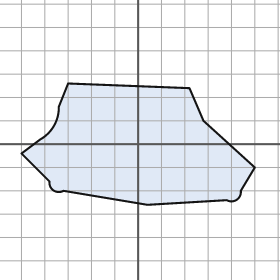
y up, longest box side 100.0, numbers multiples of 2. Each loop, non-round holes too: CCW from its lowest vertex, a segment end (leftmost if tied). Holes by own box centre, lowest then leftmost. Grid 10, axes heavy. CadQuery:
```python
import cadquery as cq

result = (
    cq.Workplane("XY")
    .moveTo(4.0, -26.0)
    .lineTo(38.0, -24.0)
    .threePointArc((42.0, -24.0), (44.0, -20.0))
    .lineTo(50.0, -10.0)
    .lineTo(28.0, 10.0)
    .lineTo(22.0, 24.0)
    .lineTo(-30.0, 26.0)
    .lineTo(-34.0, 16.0)
    .threePointArc((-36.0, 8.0), (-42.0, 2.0))
    .lineTo(-50.0, -4.0)
    .lineTo(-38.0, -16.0)
    .threePointArc((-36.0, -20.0), (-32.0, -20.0))
    .close()
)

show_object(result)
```